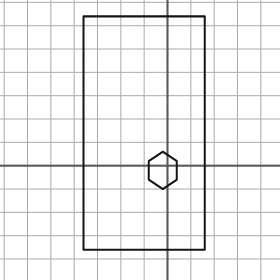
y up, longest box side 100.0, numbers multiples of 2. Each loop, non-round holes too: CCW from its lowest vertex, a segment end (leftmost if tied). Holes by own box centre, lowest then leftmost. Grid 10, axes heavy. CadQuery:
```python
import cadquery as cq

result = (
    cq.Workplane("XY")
    .moveTo(-36.0, -36.0)
    .lineTo(16.0, -36.0)
    .lineTo(16.0, 64.0)
    .lineTo(-36.0, 64.0)
    .close()
    .moveTo(-2.0, -10.0)
    .lineTo(4.0, -6.0)
    .lineTo(4.0, 2.0)
    .lineTo(-2.0, 6.0)
    .lineTo(-8.0, 2.0)
    .lineTo(-8.0, -6.0)
    .close()
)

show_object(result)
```